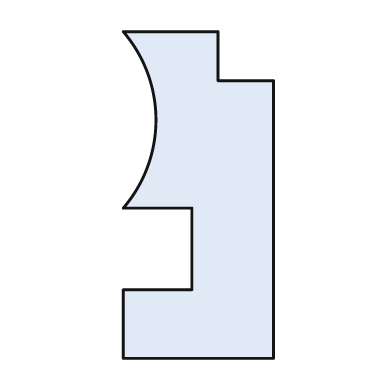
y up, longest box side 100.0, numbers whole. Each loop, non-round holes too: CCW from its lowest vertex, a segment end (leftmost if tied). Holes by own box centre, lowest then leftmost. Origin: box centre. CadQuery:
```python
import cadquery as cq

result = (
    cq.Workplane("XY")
    .moveTo(-23.0, -50.0)
    .lineTo(23.0, -50.0)
    .lineTo(23.0, 35.0)
    .lineTo(6.0, 35.0)
    .lineTo(6.0, 50.0)
    .lineTo(-23.0, 50.0)
    .threePointArc((-13.0, 23.0), (-23.0, -4.0))
    .lineTo(-2.0, -4.0)
    .lineTo(-2.0, -29.0)
    .lineTo(-23.0, -29.0)
    .close()
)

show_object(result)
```